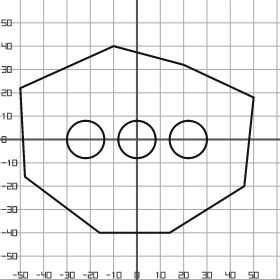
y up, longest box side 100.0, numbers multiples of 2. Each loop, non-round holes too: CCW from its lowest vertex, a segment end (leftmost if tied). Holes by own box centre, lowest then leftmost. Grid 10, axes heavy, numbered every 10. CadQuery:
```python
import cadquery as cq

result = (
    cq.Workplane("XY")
    .moveTo(-16.0, -40.0)
    .lineTo(14.0, -40.0)
    .lineTo(46.0, -20.0)
    .lineTo(50.0, 18.0)
    .lineTo(20.0, 32.0)
    .lineTo(-10.0, 40.0)
    .lineTo(-50.0, 22.0)
    .lineTo(-48.0, -16.0)
    .close()
    .moveTo(-22.0, 0.0)
    .circle(8.0)
    .moveTo(0.0, 0.0)
    .circle(8.0)
    .moveTo(22.0, 0.0)
    .circle(8.0)
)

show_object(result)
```